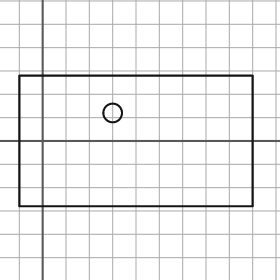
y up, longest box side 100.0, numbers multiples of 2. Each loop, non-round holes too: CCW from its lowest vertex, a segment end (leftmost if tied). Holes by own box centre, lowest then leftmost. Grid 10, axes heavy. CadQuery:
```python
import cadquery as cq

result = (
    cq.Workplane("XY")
    .moveTo(-10.0, -28.0)
    .lineTo(90.0, -28.0)
    .lineTo(90.0, 28.0)
    .lineTo(-10.0, 28.0)
    .close()
    .moveTo(30.0, 12.0)
    .circle(4.0)
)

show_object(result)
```